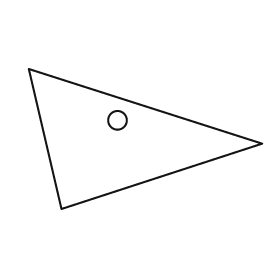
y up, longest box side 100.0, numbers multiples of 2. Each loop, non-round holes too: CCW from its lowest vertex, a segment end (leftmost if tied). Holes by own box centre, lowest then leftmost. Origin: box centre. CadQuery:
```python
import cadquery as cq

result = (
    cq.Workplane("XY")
    .moveTo(-36.0, -30.0)
    .lineTo(50.0, -2.0)
    .lineTo(-50.0, 30.0)
    .close()
    .moveTo(-12.0, 8.0)
    .circle(4.0)
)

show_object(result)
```